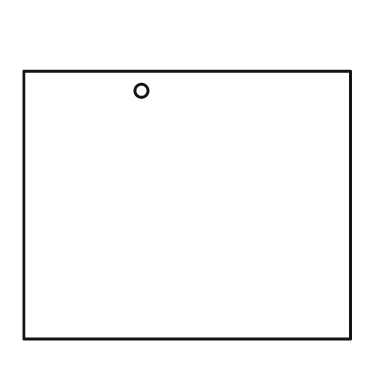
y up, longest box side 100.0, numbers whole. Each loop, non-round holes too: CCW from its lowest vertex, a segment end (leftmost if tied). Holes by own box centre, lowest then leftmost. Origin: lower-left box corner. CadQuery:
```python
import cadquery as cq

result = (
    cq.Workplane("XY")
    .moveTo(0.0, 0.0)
    .lineTo(100.0, 0.0)
    .lineTo(100.0, 82.0)
    .lineTo(0.0, 82.0)
    .close()
    .moveTo(36.0, 76.0)
    .circle(2.0)
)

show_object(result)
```